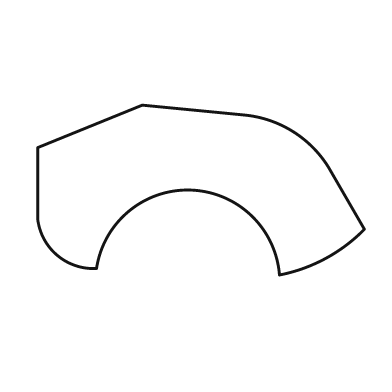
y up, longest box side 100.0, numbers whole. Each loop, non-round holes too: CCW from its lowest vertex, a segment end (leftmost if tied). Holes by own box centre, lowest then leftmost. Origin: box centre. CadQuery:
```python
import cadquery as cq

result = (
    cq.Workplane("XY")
    .moveTo(24.0, -26.0)
    .threePointArc((38.0, -21.0), (50.0, -12.0))
    .lineTo(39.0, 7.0)
    .threePointArc((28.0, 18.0), (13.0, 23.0))
    .lineTo(-18.0, 26.0)
    .lineTo(-50.0, 13.0)
    .lineTo(-50.0, -9.0)
    .threePointArc((-44.0, -20.0), (-32.0, -24.0))
    .threePointArc((-3.0, 0.0), (24.0, -26.0))
    .close()
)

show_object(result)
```